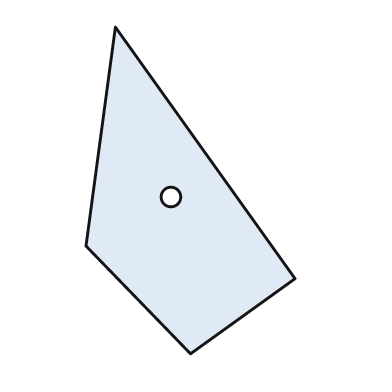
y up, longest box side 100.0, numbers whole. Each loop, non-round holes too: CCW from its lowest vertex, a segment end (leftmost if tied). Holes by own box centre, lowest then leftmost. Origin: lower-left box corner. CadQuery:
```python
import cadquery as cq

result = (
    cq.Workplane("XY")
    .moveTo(32.0, 0.0)
    .lineTo(64.0, 23.0)
    .lineTo(9.0, 100.0)
    .lineTo(0.0, 33.0)
    .close()
    .moveTo(26.0, 48.0)
    .circle(3.0)
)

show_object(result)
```